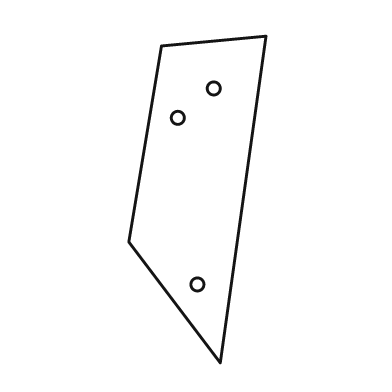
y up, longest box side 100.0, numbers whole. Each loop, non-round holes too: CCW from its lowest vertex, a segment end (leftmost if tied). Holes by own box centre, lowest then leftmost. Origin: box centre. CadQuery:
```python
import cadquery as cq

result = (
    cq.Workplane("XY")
    .moveTo(7.0, -50.0)
    .lineTo(21.0, 50.0)
    .lineTo(-11.0, 47.0)
    .lineTo(-21.0, -13.0)
    .close()
    .moveTo(0.0, -26.0)
    .circle(2.0)
    .moveTo(-6.0, 25.0)
    .circle(2.0)
    .moveTo(5.0, 34.0)
    .circle(2.0)
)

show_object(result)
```